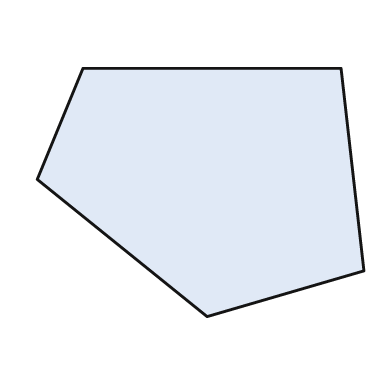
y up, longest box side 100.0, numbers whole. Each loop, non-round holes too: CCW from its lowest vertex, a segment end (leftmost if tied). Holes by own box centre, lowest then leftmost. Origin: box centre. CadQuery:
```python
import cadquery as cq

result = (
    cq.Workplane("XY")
    .moveTo(2.0, -38.0)
    .lineTo(50.0, -24.0)
    .lineTo(43.0, 38.0)
    .lineTo(-36.0, 38.0)
    .lineTo(-50.0, 4.0)
    .close()
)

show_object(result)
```